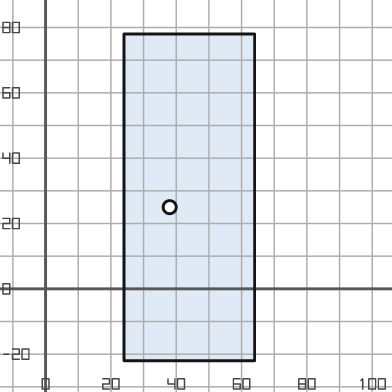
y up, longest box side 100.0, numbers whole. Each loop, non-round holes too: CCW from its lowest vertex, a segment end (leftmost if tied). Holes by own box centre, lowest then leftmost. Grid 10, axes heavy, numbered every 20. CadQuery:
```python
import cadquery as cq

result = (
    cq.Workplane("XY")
    .moveTo(24.0, -22.0)
    .lineTo(64.0, -22.0)
    .lineTo(64.0, 78.0)
    .lineTo(24.0, 78.0)
    .close()
    .moveTo(38.0, 25.0)
    .circle(2.0)
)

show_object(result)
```